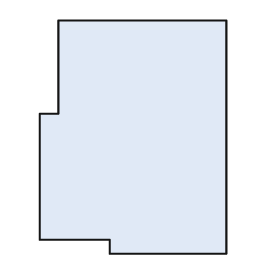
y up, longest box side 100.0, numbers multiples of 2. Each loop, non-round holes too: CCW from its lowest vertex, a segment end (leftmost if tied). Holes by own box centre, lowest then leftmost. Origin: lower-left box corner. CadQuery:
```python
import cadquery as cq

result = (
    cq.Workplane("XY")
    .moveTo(30.0, 0.0)
    .lineTo(80.0, 0.0)
    .lineTo(80.0, 100.0)
    .lineTo(8.0, 100.0)
    .lineTo(8.0, 60.0)
    .lineTo(0.0, 60.0)
    .lineTo(0.0, 6.0)
    .lineTo(30.0, 6.0)
    .close()
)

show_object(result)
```